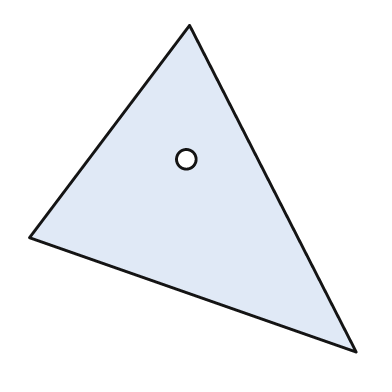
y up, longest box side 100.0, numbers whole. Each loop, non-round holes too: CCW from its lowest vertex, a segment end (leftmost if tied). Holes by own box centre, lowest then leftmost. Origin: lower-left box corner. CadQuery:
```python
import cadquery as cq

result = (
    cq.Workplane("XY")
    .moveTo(100.0, 0.0)
    .lineTo(49.0, 100.0)
    .lineTo(0.0, 35.0)
    .close()
    .moveTo(48.0, 59.0)
    .circle(3.0)
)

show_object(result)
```